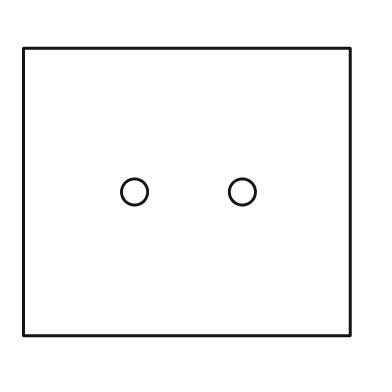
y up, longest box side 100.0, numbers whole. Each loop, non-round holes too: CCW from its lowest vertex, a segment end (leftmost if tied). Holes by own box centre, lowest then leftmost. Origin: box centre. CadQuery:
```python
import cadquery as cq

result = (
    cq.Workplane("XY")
    .moveTo(-50.0, -44.0)
    .lineTo(50.0, -44.0)
    .lineTo(50.0, 44.0)
    .lineTo(-50.0, 44.0)
    .close()
    .moveTo(-16.0, 0.0)
    .circle(4.0)
    .moveTo(17.0, 0.0)
    .circle(4.0)
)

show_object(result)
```